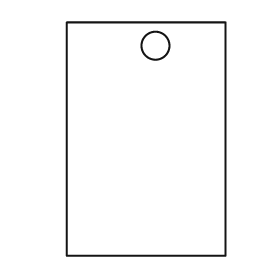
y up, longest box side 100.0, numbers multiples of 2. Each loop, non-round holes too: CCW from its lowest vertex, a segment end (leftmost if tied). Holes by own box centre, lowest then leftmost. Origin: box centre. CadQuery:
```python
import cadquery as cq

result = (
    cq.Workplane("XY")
    .moveTo(-34.0, -50.0)
    .lineTo(34.0, -50.0)
    .lineTo(34.0, 50.0)
    .lineTo(-34.0, 50.0)
    .close()
    .moveTo(4.0, 40.0)
    .circle(6.0)
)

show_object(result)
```